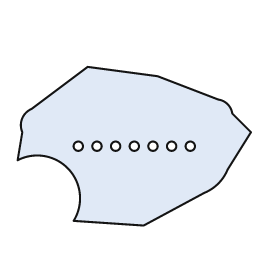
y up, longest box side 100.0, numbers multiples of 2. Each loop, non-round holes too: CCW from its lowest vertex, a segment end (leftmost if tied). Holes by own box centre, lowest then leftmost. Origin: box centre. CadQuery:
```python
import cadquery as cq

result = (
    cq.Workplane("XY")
    .moveTo(4.0, -34.0)
    .lineTo(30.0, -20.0)
    .threePointArc((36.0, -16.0), (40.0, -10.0))
    .lineTo(50.0, 6.0)
    .lineTo(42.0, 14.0)
    .threePointArc((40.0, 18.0), (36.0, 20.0))
    .lineTo(10.0, 30.0)
    .lineTo(-20.0, 34.0)
    .lineTo(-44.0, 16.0)
    .threePointArc((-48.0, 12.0), (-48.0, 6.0))
    .lineTo(-50.0, -6.0)
    .threePointArc((-28.0, -10.0), (-26.0, -32.0))
    .close()
    .moveTo(-24.0, 0.0)
    .circle(2.0)
    .moveTo(-16.0, 0.0)
    .circle(2.0)
    .moveTo(-8.0, 0.0)
    .circle(2.0)
    .moveTo(0.0, 0.0)
    .circle(2.0)
    .moveTo(8.0, 0.0)
    .circle(2.0)
    .moveTo(16.0, 0.0)
    .circle(2.0)
    .moveTo(24.0, 0.0)
    .circle(2.0)
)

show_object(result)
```